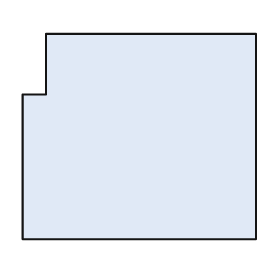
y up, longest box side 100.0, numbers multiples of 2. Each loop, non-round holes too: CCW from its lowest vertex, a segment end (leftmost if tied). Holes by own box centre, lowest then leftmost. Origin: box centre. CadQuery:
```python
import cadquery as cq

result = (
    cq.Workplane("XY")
    .moveTo(-50.0, -44.0)
    .lineTo(50.0, -44.0)
    .lineTo(50.0, 44.0)
    .lineTo(-40.0, 44.0)
    .lineTo(-40.0, 18.0)
    .lineTo(-50.0, 18.0)
    .close()
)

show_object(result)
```